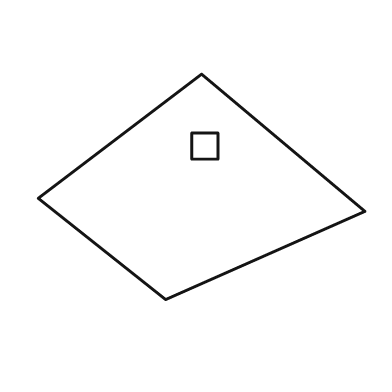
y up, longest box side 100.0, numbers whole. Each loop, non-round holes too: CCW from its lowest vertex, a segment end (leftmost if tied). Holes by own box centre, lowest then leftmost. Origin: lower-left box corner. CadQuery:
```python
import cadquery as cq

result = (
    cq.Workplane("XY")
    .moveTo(39.0, 0.0)
    .lineTo(100.0, 27.0)
    .lineTo(50.0, 69.0)
    .lineTo(0.0, 31.0)
    .close()
    .moveTo(47.0, 43.0)
    .lineTo(55.0, 43.0)
    .lineTo(55.0, 51.0)
    .lineTo(47.0, 51.0)
    .close()
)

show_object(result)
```